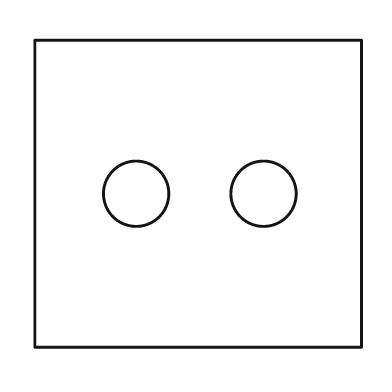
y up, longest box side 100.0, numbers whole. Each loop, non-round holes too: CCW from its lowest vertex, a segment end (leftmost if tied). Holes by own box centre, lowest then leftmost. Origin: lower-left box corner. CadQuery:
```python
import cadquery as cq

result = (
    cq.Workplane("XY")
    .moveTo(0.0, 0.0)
    .lineTo(100.0, 0.0)
    .lineTo(100.0, 94.0)
    .lineTo(0.0, 94.0)
    .close()
    .moveTo(31.0, 47.0)
    .circle(10.0)
    .moveTo(70.0, 47.0)
    .circle(10.0)
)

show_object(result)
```